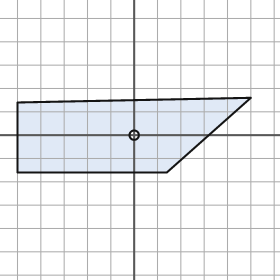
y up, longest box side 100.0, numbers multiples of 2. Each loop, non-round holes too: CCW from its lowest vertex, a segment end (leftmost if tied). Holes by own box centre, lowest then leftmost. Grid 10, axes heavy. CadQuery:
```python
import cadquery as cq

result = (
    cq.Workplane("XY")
    .moveTo(-50.0, -16.0)
    .lineTo(14.0, -16.0)
    .lineTo(50.0, 16.0)
    .lineTo(-50.0, 14.0)
    .close()
    .moveTo(0.0, 0.0)
    .circle(2.0)
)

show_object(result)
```